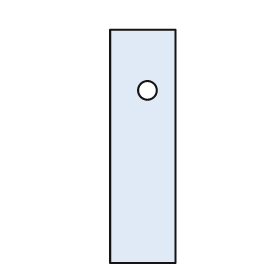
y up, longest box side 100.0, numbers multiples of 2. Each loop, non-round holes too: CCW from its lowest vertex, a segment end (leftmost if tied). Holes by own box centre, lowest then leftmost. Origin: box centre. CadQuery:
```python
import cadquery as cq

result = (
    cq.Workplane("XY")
    .moveTo(-14.0, -50.0)
    .lineTo(14.0, -50.0)
    .lineTo(14.0, 50.0)
    .lineTo(-14.0, 50.0)
    .close()
    .moveTo(2.0, 24.0)
    .circle(4.0)
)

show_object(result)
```